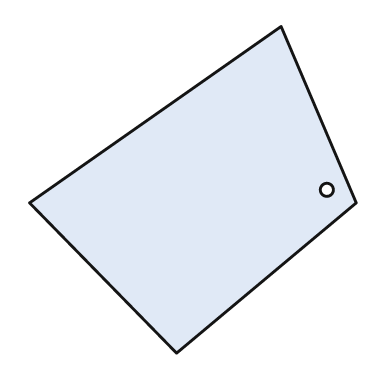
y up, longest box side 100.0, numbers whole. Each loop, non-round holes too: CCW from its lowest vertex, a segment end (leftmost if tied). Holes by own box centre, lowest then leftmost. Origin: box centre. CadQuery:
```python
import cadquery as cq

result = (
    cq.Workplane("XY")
    .moveTo(-5.0, -50.0)
    .lineTo(50.0, -4.0)
    .lineTo(27.0, 50.0)
    .lineTo(-50.0, -4.0)
    .close()
    .moveTo(41.0, 0.0)
    .circle(2.0)
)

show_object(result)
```